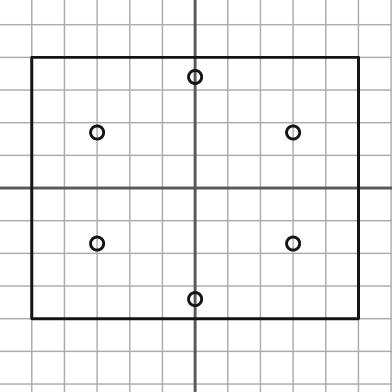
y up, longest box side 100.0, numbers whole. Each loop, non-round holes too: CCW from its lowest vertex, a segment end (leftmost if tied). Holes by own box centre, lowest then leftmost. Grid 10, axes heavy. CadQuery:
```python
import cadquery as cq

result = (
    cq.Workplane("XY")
    .moveTo(-50.0, -40.0)
    .lineTo(50.0, -40.0)
    .lineTo(50.0, 40.0)
    .lineTo(-50.0, 40.0)
    .close()
    .moveTo(0.0, -34.0)
    .circle(2.0)
    .moveTo(-30.0, -17.0)
    .circle(2.0)
    .moveTo(30.0, -17.0)
    .circle(2.0)
    .moveTo(-30.0, 17.0)
    .circle(2.0)
    .moveTo(30.0, 17.0)
    .circle(2.0)
    .moveTo(0.0, 34.0)
    .circle(2.0)
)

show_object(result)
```